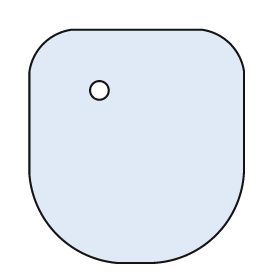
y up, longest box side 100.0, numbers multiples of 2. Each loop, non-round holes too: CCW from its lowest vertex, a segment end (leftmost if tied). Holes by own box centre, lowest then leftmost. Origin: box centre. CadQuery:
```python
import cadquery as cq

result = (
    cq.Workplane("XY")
    .moveTo(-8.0, -50.0)
    .lineTo(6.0, -50.0)
    .threePointArc((34.0, -38.0), (46.0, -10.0))
    .lineTo(46.0, 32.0)
    .threePointArc((40.0, 44.0), (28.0, 50.0))
    .lineTo(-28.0, 50.0)
    .threePointArc((-40.0, 44.0), (-46.0, 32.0))
    .lineTo(-46.0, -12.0)
    .threePointArc((-34.0, -38.0), (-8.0, -50.0))
    .close()
    .moveTo(-16.0, 24.0)
    .circle(4.0)
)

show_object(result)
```